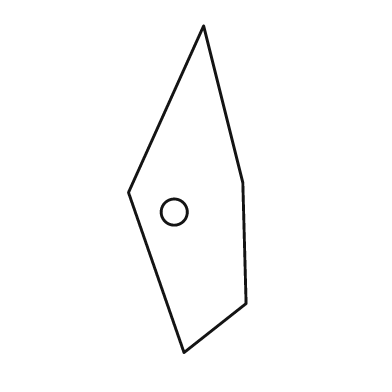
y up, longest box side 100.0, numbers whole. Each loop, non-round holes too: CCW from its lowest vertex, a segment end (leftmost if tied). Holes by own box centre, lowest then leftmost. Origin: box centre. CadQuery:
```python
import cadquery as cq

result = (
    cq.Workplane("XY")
    .moveTo(-1.0, -50.0)
    .lineTo(18.0, -35.0)
    .lineTo(17.0, 2.0)
    .lineTo(5.0, 50.0)
    .lineTo(-18.0, -1.0)
    .close()
    .moveTo(-4.0, -7.0)
    .circle(4.0)
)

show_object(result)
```